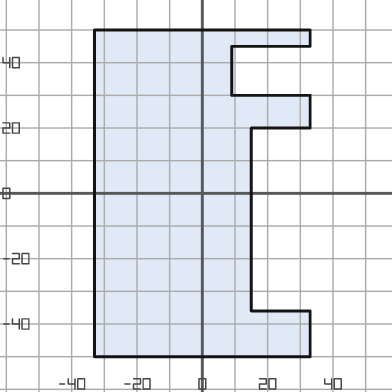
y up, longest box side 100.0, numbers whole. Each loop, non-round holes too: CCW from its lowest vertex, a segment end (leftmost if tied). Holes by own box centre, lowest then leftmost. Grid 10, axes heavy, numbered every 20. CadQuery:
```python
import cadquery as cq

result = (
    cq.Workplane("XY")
    .moveTo(-33.0, -50.0)
    .lineTo(33.0, -50.0)
    .lineTo(33.0, -36.0)
    .lineTo(15.0, -36.0)
    .lineTo(15.0, 20.0)
    .lineTo(33.0, 20.0)
    .lineTo(33.0, 30.0)
    .lineTo(9.0, 30.0)
    .lineTo(9.0, 45.0)
    .lineTo(33.0, 45.0)
    .lineTo(33.0, 50.0)
    .lineTo(-33.0, 50.0)
    .close()
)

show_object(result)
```